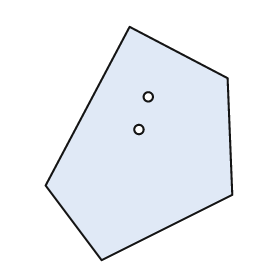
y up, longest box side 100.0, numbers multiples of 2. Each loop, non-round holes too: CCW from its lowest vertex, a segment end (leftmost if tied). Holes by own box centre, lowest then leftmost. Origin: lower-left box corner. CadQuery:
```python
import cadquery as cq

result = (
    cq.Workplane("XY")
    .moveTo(24.0, 0.0)
    .lineTo(80.0, 28.0)
    .lineTo(78.0, 78.0)
    .lineTo(36.0, 100.0)
    .lineTo(0.0, 32.0)
    .close()
    .moveTo(40.0, 56.0)
    .circle(2.0)
    .moveTo(44.0, 70.0)
    .circle(2.0)
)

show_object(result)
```